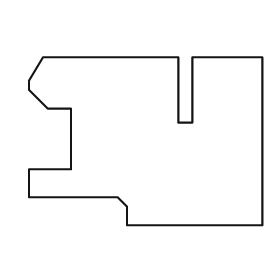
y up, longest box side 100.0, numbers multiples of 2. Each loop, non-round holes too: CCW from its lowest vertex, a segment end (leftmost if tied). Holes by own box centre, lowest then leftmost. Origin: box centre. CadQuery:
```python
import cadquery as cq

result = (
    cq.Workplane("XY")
    .moveTo(-8.0, -36.0)
    .lineTo(50.0, -36.0)
    .lineTo(50.0, 36.0)
    .lineTo(20.0, 36.0)
    .lineTo(20.0, 8.0)
    .lineTo(14.0, 8.0)
    .lineTo(14.0, 36.0)
    .lineTo(-44.0, 36.0)
    .lineTo(-50.0, 26.0)
    .lineTo(-50.0, 22.0)
    .lineTo(-42.0, 14.0)
    .lineTo(-32.0, 14.0)
    .lineTo(-32.0, -12.0)
    .lineTo(-50.0, -12.0)
    .lineTo(-50.0, -24.0)
    .lineTo(-12.0, -24.0)
    .lineTo(-8.0, -28.0)
    .close()
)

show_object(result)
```